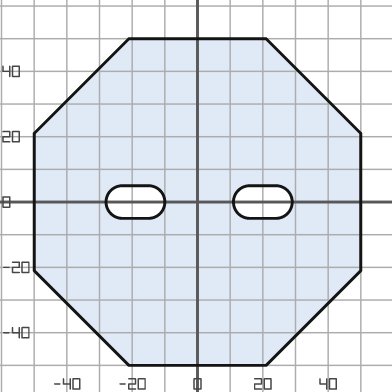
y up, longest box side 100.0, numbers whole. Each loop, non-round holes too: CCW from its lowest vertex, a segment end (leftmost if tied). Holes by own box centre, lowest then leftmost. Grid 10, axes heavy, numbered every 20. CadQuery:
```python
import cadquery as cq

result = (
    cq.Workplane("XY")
    .moveTo(-21.0, -50.0)
    .lineTo(21.0, -50.0)
    .lineTo(50.0, -21.0)
    .lineTo(50.0, 21.0)
    .lineTo(21.0, 50.0)
    .lineTo(-21.0, 50.0)
    .lineTo(-50.0, 21.0)
    .lineTo(-50.0, -21.0)
    .close()
    .moveTo(-23.0, -5.0)
    .lineTo(-15.0, -5.0)
    .threePointArc((-10.0, 0.0), (-15.0, 5.0))
    .lineTo(-23.0, 5.0)
    .threePointArc((-28.0, 0.0), (-23.0, -5.0))
    .close()
    .moveTo(16.0, -5.0)
    .lineTo(24.0, -5.0)
    .threePointArc((29.0, 0.0), (24.0, 5.0))
    .lineTo(16.0, 5.0)
    .threePointArc((11.0, 0.0), (16.0, -5.0))
    .close()
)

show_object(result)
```